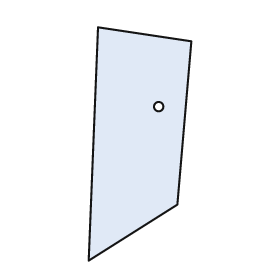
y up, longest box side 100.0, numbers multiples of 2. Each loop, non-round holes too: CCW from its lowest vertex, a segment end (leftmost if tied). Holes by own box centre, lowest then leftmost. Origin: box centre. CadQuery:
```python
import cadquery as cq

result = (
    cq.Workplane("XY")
    .moveTo(-22.0, -50.0)
    .lineTo(16.0, -26.0)
    .lineTo(22.0, 44.0)
    .lineTo(-18.0, 50.0)
    .close()
    .moveTo(8.0, 16.0)
    .circle(2.0)
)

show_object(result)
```